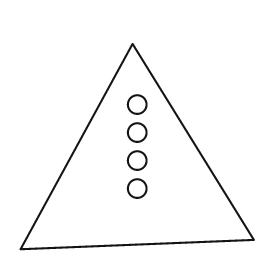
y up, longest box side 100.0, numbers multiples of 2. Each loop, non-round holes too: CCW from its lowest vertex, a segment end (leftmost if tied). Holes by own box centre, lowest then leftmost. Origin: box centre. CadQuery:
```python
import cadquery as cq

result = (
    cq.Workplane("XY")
    .moveTo(-50.0, -44.0)
    .lineTo(50.0, -40.0)
    .lineTo(-2.0, 44.0)
    .close()
    .moveTo(0.0, -18.0)
    .circle(4.0)
    .moveTo(0.0, -6.0)
    .circle(4.0)
    .moveTo(0.0, 6.0)
    .circle(4.0)
    .moveTo(0.0, 18.0)
    .circle(4.0)
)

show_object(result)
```